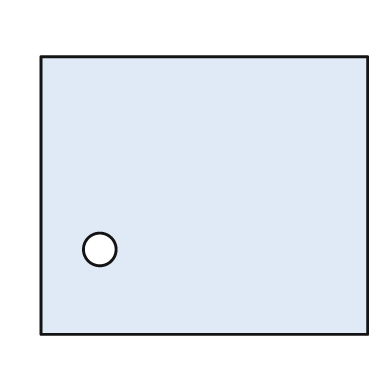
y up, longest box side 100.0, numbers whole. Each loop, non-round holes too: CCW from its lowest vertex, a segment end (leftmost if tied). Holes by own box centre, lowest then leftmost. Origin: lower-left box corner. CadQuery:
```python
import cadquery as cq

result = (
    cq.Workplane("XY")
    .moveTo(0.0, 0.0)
    .lineTo(100.0, 0.0)
    .lineTo(100.0, 85.0)
    .lineTo(0.0, 85.0)
    .close()
    .moveTo(18.0, 26.0)
    .circle(5.0)
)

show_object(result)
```